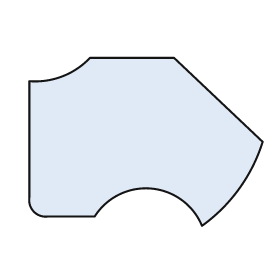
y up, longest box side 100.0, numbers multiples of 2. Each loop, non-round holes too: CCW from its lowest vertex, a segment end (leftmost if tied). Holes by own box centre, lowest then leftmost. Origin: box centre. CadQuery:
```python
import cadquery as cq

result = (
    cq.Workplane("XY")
    .moveTo(24.0, -36.0)
    .threePointArc((40.0, -20.0), (50.0, 0.0))
    .lineTo(12.0, 36.0)
    .lineTo(-24.0, 36.0)
    .threePointArc((-36.0, 28.0), (-50.0, 26.0))
    .lineTo(-50.0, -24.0)
    .threePointArc((-48.0, -30.0), (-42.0, -32.0))
    .lineTo(-22.0, -32.0)
    .threePointArc((2.0, -20.0), (24.0, -36.0))
    .close()
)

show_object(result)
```